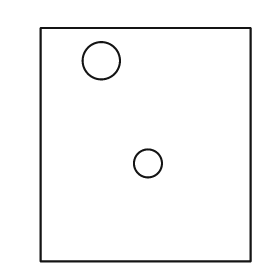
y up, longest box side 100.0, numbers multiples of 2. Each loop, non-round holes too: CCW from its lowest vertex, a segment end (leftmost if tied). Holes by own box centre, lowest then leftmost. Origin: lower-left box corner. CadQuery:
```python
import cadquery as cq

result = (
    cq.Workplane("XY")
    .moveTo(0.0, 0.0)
    .lineTo(90.0, 0.0)
    .lineTo(90.0, 100.0)
    .lineTo(0.0, 100.0)
    .close()
    .moveTo(46.0, 42.0)
    .circle(6.0)
    .moveTo(26.0, 86.0)
    .circle(8.0)
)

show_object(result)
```